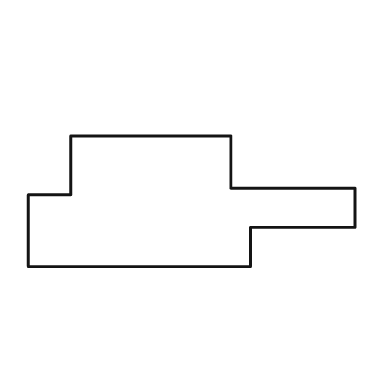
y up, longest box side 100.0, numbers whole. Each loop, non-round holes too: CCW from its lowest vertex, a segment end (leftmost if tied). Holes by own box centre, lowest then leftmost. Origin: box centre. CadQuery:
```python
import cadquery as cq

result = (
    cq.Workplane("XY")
    .moveTo(-50.0, -20.0)
    .lineTo(18.0, -20.0)
    .lineTo(18.0, -8.0)
    .lineTo(50.0, -8.0)
    .lineTo(50.0, 4.0)
    .lineTo(12.0, 4.0)
    .lineTo(12.0, 20.0)
    .lineTo(-37.0, 20.0)
    .lineTo(-37.0, 2.0)
    .lineTo(-50.0, 2.0)
    .close()
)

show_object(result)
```